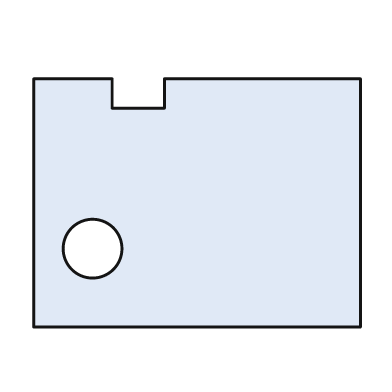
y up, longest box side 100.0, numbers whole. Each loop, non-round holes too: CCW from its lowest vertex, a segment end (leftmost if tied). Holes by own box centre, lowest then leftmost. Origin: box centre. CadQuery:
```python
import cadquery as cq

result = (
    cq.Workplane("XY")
    .moveTo(-50.0, -38.0)
    .lineTo(50.0, -38.0)
    .lineTo(50.0, 38.0)
    .lineTo(-10.0, 38.0)
    .lineTo(-10.0, 29.0)
    .lineTo(-26.0, 29.0)
    .lineTo(-26.0, 38.0)
    .lineTo(-50.0, 38.0)
    .close()
    .moveTo(-32.0, -14.0)
    .circle(9.0)
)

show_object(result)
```